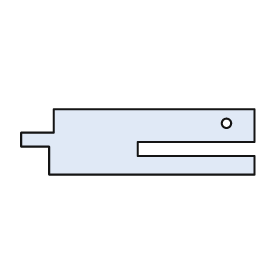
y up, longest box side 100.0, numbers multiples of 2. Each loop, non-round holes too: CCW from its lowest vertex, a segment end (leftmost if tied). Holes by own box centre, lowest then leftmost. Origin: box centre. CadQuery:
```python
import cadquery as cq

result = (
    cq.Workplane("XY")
    .moveTo(-38.0, -14.0)
    .lineTo(50.0, -14.0)
    .lineTo(50.0, -6.0)
    .lineTo(0.0, -6.0)
    .lineTo(0.0, 0.0)
    .lineTo(50.0, 0.0)
    .lineTo(50.0, 14.0)
    .lineTo(-36.0, 14.0)
    .lineTo(-36.0, 4.0)
    .lineTo(-50.0, 4.0)
    .lineTo(-50.0, -2.0)
    .lineTo(-38.0, -2.0)
    .close()
    .moveTo(38.0, 8.0)
    .circle(2.0)
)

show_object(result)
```